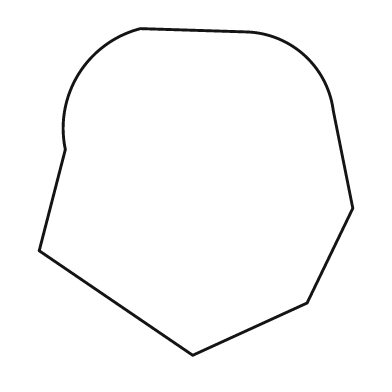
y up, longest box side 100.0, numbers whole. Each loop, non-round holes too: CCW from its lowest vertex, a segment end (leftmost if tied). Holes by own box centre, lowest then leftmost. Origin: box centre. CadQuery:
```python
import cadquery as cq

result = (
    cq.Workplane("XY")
    .moveTo(-1.0, -50.0)
    .lineTo(34.0, -34.0)
    .lineTo(48.0, -5.0)
    .lineTo(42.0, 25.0)
    .threePointArc((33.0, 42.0), (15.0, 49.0))
    .lineTo(-17.0, 50.0)
    .threePointArc((-36.0, 36.0), (-40.0, 13.0))
    .lineTo(-48.0, -18.0)
    .close()
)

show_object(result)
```